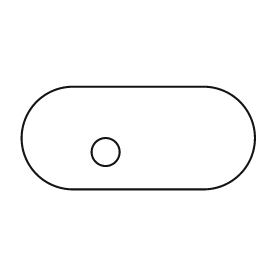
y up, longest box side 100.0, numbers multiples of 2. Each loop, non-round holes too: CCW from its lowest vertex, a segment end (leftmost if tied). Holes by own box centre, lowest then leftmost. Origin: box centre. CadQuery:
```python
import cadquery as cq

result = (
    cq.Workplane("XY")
    .moveTo(-28.0, -22.0)
    .lineTo(28.0, -22.0)
    .threePointArc((50.0, 0.0), (28.0, 22.0))
    .lineTo(-28.0, 22.0)
    .threePointArc((-50.0, 0.0), (-28.0, -22.0))
    .close()
    .moveTo(-14.0, -6.0)
    .circle(6.0)
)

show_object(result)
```